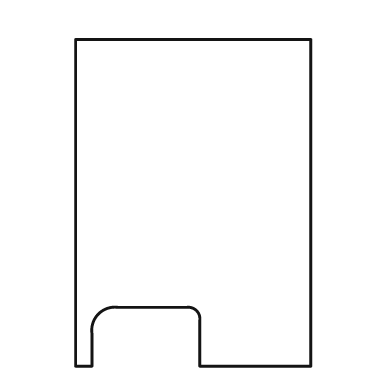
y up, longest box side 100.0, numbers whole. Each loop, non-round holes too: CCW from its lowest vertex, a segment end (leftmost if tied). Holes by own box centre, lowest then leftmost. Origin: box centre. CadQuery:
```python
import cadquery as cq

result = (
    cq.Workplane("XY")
    .moveTo(-36.0, -50.0)
    .lineTo(-31.0, -50.0)
    .lineTo(-31.0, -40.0)
    .threePointArc((-29.0, -34.0), (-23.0, -32.0))
    .lineTo(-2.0, -32.0)
    .threePointArc((1.0, -33.0), (2.0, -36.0))
    .lineTo(2.0, -50.0)
    .lineTo(36.0, -50.0)
    .lineTo(36.0, 50.0)
    .lineTo(-36.0, 50.0)
    .close()
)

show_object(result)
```